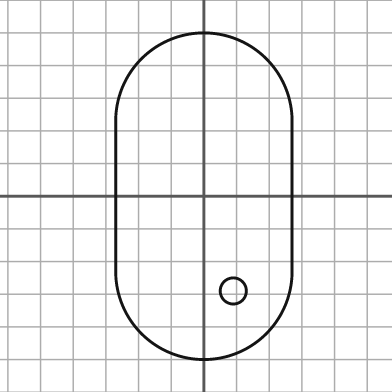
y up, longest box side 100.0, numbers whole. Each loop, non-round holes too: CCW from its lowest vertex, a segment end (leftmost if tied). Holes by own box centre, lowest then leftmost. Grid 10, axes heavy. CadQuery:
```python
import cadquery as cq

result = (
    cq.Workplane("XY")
    .moveTo(-27.0, -23.0)
    .threePointArc((0.0, -50.0), (27.0, -23.0))
    .lineTo(27.0, 23.0)
    .threePointArc((0.0, 50.0), (-27.0, 23.0))
    .close()
    .moveTo(9.0, -29.0)
    .circle(4.0)
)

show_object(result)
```